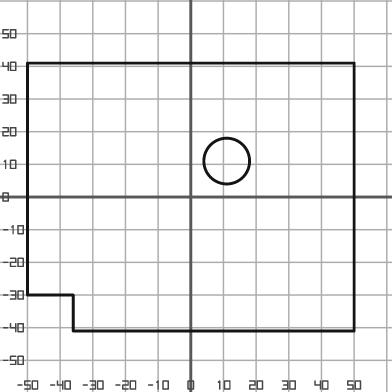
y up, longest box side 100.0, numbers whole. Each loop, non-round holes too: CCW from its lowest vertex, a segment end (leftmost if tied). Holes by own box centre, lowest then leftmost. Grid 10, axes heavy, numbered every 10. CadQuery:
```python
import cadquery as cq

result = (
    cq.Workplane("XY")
    .moveTo(-36.0, -41.0)
    .lineTo(50.0, -41.0)
    .lineTo(50.0, 41.0)
    .lineTo(-50.0, 41.0)
    .lineTo(-50.0, -30.0)
    .lineTo(-36.0, -30.0)
    .close()
    .moveTo(11.0, 11.0)
    .circle(7.0)
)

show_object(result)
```